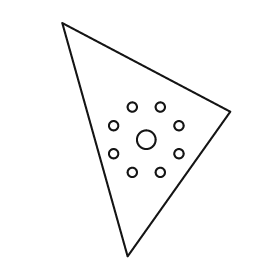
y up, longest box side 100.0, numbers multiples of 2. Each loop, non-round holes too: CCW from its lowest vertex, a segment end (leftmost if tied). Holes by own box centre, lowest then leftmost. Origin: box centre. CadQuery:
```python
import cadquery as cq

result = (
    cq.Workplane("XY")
    .moveTo(-8.0, -50.0)
    .lineTo(36.0, 12.0)
    .lineTo(-36.0, 50.0)
    .close()
    .moveTo(-6.0, -14.0)
    .circle(2.0)
    .moveTo(6.0, -14.0)
    .circle(2.0)
    .moveTo(-14.0, -6.0)
    .circle(2.0)
    .moveTo(14.0, -6.0)
    .circle(2.0)
    .moveTo(0.0, 0.0)
    .circle(4.0)
    .moveTo(-14.0, 6.0)
    .circle(2.0)
    .moveTo(14.0, 6.0)
    .circle(2.0)
    .moveTo(-6.0, 14.0)
    .circle(2.0)
    .moveTo(6.0, 14.0)
    .circle(2.0)
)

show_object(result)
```